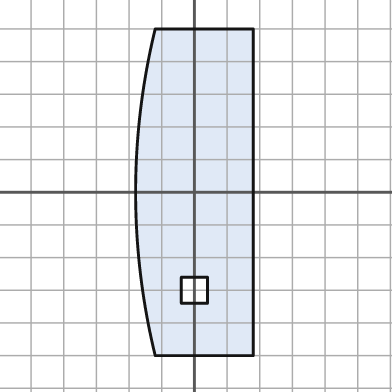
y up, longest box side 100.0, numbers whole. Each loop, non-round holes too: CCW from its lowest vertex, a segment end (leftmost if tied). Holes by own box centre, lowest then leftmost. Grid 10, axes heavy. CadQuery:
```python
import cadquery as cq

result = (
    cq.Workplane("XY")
    .moveTo(-12.0, -50.0)
    .lineTo(18.0, -50.0)
    .lineTo(18.0, 50.0)
    .lineTo(-12.0, 50.0)
    .threePointArc((-18.0, 0.0), (-12.0, -50.0))
    .close()
    .moveTo(-4.0, -34.0)
    .lineTo(4.0, -34.0)
    .lineTo(4.0, -26.0)
    .lineTo(-4.0, -26.0)
    .close()
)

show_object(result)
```